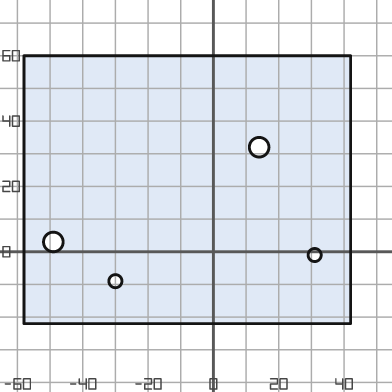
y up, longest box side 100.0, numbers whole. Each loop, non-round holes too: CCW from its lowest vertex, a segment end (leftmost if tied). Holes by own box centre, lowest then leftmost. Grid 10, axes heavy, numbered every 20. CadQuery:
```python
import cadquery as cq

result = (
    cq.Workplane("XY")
    .moveTo(-58.0, -22.0)
    .lineTo(42.0, -22.0)
    .lineTo(42.0, 60.0)
    .lineTo(-58.0, 60.0)
    .close()
    .moveTo(-30.0, -9.0)
    .circle(2.0)
    .moveTo(31.0, -1.0)
    .circle(2.0)
    .moveTo(-49.0, 3.0)
    .circle(3.0)
    .moveTo(14.0, 32.0)
    .circle(3.0)
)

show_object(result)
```